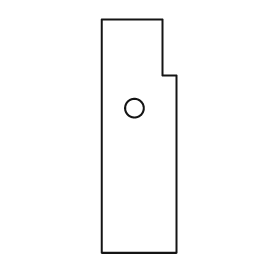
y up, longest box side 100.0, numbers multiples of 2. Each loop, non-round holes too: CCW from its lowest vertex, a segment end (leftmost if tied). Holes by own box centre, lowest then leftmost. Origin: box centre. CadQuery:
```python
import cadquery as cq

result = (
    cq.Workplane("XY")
    .moveTo(-16.0, -50.0)
    .lineTo(16.0, -50.0)
    .lineTo(16.0, 26.0)
    .lineTo(10.0, 26.0)
    .lineTo(10.0, 50.0)
    .lineTo(-16.0, 50.0)
    .close()
    .moveTo(-2.0, 12.0)
    .circle(4.0)
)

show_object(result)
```